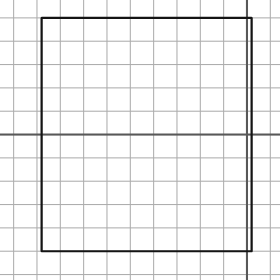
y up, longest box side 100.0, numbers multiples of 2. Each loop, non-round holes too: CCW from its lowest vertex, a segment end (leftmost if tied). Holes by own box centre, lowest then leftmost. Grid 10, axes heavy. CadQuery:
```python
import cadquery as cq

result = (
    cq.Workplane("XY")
    .moveTo(-88.0, -50.0)
    .lineTo(2.0, -50.0)
    .lineTo(2.0, 50.0)
    .lineTo(-88.0, 50.0)
    .close()
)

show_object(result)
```